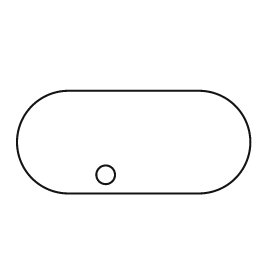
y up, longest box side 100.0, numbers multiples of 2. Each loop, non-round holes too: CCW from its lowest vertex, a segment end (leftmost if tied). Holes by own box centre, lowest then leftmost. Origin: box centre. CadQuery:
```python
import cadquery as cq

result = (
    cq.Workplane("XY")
    .moveTo(-28.0, -22.0)
    .lineTo(28.0, -22.0)
    .threePointArc((50.0, 0.0), (28.0, 22.0))
    .lineTo(-28.0, 22.0)
    .threePointArc((-50.0, 0.0), (-28.0, -22.0))
    .close()
    .moveTo(-12.0, -14.0)
    .circle(4.0)
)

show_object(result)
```